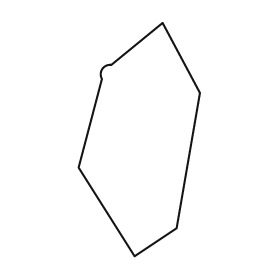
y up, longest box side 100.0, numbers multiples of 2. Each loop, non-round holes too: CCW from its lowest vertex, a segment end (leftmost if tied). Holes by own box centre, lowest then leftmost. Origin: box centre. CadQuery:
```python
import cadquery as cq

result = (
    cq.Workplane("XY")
    .moveTo(-2.0, -50.0)
    .lineTo(16.0, -38.0)
    .lineTo(26.0, 20.0)
    .lineTo(10.0, 50.0)
    .lineTo(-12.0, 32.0)
    .threePointArc((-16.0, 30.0), (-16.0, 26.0))
    .lineTo(-26.0, -12.0)
    .close()
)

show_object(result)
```